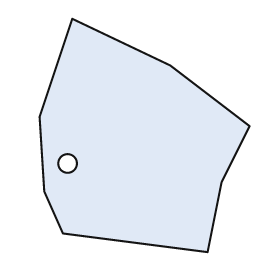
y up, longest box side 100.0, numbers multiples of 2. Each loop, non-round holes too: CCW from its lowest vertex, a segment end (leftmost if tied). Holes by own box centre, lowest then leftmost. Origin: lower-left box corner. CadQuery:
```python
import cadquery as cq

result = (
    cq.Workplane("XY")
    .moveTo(72.0, 0.0)
    .lineTo(78.0, 30.0)
    .lineTo(90.0, 54.0)
    .lineTo(56.0, 80.0)
    .lineTo(14.0, 100.0)
    .lineTo(0.0, 58.0)
    .lineTo(2.0, 26.0)
    .lineTo(10.0, 8.0)
    .close()
    .moveTo(12.0, 38.0)
    .circle(4.0)
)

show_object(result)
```